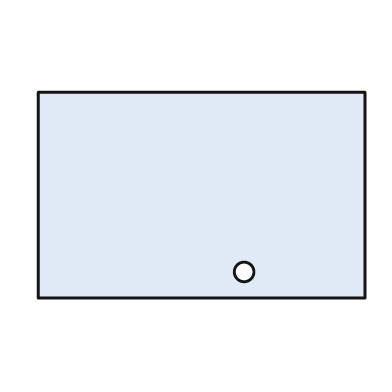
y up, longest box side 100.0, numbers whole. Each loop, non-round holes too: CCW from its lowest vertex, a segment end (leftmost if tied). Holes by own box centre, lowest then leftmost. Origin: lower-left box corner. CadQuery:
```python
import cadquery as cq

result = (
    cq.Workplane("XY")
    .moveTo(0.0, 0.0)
    .lineTo(100.0, 0.0)
    .lineTo(100.0, 63.0)
    .lineTo(0.0, 63.0)
    .close()
    .moveTo(63.0, 8.0)
    .circle(3.0)
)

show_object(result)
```